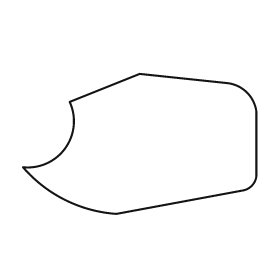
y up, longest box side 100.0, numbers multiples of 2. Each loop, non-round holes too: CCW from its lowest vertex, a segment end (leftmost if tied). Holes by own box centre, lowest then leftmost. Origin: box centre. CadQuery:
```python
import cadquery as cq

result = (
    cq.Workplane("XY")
    .moveTo(-10.0, -30.0)
    .lineTo(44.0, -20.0)
    .threePointArc((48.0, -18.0), (50.0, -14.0))
    .lineTo(50.0, 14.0)
    .threePointArc((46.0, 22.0), (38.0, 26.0))
    .lineTo(0.0, 30.0)
    .lineTo(-30.0, 18.0)
    .threePointArc((-32.0, -2.0), (-50.0, -10.0))
    .threePointArc((-32.0, -24.0), (-10.0, -30.0))
    .close()
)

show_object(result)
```